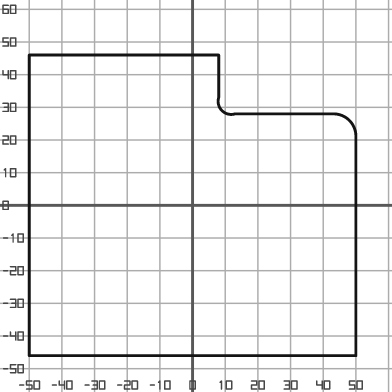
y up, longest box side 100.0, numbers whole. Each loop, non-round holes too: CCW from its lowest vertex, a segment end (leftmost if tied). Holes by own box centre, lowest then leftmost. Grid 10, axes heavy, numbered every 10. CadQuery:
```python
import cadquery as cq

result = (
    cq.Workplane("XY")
    .moveTo(-50.0, -46.0)
    .lineTo(50.0, -46.0)
    .lineTo(50.0, 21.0)
    .threePointArc((48.0, 26.0), (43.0, 28.0))
    .lineTo(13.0, 28.0)
    .threePointArc((9.0, 29.0), (8.0, 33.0))
    .lineTo(8.0, 46.0)
    .lineTo(-50.0, 46.0)
    .close()
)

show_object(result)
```